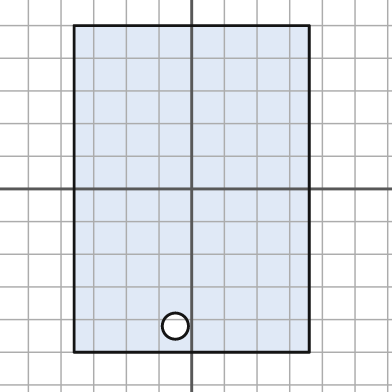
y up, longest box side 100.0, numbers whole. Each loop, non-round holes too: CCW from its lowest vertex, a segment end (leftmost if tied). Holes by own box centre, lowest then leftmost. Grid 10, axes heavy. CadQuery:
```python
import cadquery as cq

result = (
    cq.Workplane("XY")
    .moveTo(-36.0, -50.0)
    .lineTo(36.0, -50.0)
    .lineTo(36.0, 50.0)
    .lineTo(-36.0, 50.0)
    .close()
    .moveTo(-5.0, -42.0)
    .circle(4.0)
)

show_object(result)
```